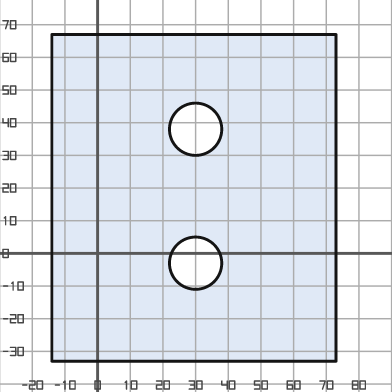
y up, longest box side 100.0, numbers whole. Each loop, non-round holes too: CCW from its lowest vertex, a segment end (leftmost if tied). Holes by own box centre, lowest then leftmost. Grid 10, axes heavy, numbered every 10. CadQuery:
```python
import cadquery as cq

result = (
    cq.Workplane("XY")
    .moveTo(-14.0, -33.0)
    .lineTo(73.0, -33.0)
    .lineTo(73.0, 67.0)
    .lineTo(-14.0, 67.0)
    .close()
    .moveTo(30.0, -3.0)
    .circle(8.0)
    .moveTo(30.0, 38.0)
    .circle(8.0)
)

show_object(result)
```